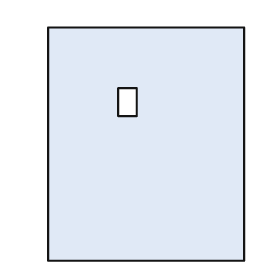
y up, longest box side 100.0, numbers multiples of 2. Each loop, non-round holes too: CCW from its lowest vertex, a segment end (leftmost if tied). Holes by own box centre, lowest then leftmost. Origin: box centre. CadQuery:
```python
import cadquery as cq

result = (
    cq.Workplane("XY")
    .moveTo(-42.0, -50.0)
    .lineTo(42.0, -50.0)
    .lineTo(42.0, 50.0)
    .lineTo(-42.0, 50.0)
    .close()
    .moveTo(-12.0, 12.0)
    .lineTo(-4.0, 12.0)
    .lineTo(-4.0, 24.0)
    .lineTo(-12.0, 24.0)
    .close()
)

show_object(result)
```